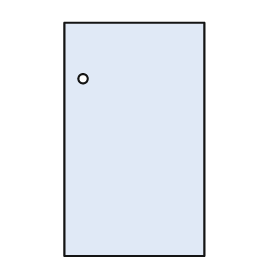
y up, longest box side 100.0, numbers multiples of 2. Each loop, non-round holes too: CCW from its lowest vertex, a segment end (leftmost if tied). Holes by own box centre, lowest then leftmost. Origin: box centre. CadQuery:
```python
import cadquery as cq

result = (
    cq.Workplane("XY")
    .moveTo(-30.0, -50.0)
    .lineTo(30.0, -50.0)
    .lineTo(30.0, 50.0)
    .lineTo(-30.0, 50.0)
    .close()
    .moveTo(-22.0, 26.0)
    .circle(2.0)
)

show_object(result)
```